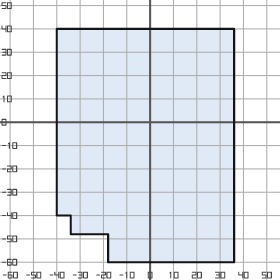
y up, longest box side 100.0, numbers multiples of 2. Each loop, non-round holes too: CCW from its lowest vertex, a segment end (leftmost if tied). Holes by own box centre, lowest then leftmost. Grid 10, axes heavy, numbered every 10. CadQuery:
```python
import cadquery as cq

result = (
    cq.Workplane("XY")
    .moveTo(-18.0, -60.0)
    .lineTo(36.0, -60.0)
    .lineTo(36.0, 40.0)
    .lineTo(-40.0, 40.0)
    .lineTo(-40.0, -40.0)
    .lineTo(-34.0, -40.0)
    .lineTo(-34.0, -48.0)
    .lineTo(-18.0, -48.0)
    .close()
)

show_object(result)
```